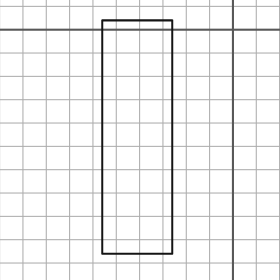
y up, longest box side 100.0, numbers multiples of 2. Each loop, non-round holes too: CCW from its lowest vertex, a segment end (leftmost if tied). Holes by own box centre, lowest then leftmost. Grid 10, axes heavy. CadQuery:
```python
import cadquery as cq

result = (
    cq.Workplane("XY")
    .moveTo(-56.0, -96.0)
    .lineTo(-26.0, -96.0)
    .lineTo(-26.0, 4.0)
    .lineTo(-56.0, 4.0)
    .close()
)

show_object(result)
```